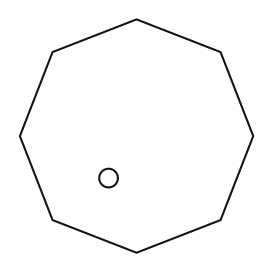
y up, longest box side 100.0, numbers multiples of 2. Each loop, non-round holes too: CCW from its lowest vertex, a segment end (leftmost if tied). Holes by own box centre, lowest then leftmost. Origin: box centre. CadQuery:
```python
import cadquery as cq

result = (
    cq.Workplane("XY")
    .moveTo(0.0, -50.0)
    .lineTo(36.0, -36.0)
    .lineTo(50.0, 0.0)
    .lineTo(36.0, 36.0)
    .lineTo(0.0, 50.0)
    .lineTo(-36.0, 36.0)
    .lineTo(-50.0, 0.0)
    .lineTo(-36.0, -36.0)
    .close()
    .moveTo(-12.0, -18.0)
    .circle(4.0)
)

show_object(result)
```